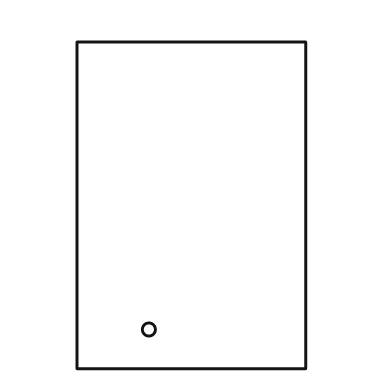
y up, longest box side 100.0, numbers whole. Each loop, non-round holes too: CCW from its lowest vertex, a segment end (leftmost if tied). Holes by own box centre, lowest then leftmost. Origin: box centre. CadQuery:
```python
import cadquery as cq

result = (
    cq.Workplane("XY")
    .moveTo(-35.0, -50.0)
    .lineTo(35.0, -50.0)
    .lineTo(35.0, 50.0)
    .lineTo(-35.0, 50.0)
    .close()
    .moveTo(-13.0, -38.0)
    .circle(2.0)
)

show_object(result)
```